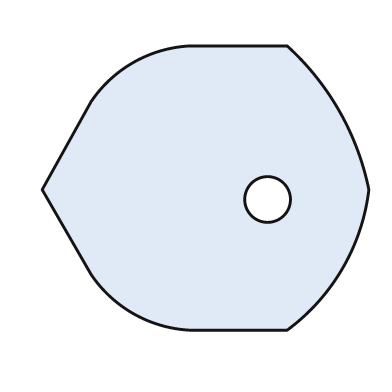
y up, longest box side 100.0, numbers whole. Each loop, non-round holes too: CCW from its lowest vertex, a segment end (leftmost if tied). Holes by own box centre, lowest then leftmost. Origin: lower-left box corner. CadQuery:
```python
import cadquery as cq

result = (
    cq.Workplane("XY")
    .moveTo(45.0, 0.0)
    .lineTo(75.0, 0.0)
    .threePointArc((92.0, 19.0), (100.0, 43.0))
    .threePointArc((91.0, 67.0), (75.0, 87.0))
    .lineTo(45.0, 87.0)
    .threePointArc((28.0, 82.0), (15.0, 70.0))
    .lineTo(0.0, 43.0)
    .lineTo(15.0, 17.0)
    .threePointArc((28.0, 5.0), (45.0, 0.0))
    .close()
    .moveTo(69.0, 40.0)
    .circle(7.0)
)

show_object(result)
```